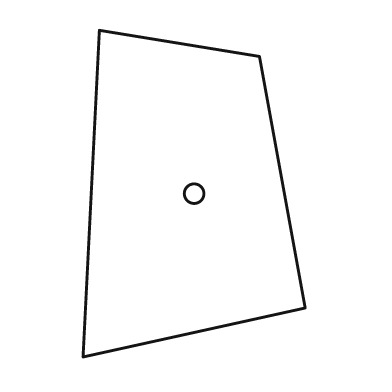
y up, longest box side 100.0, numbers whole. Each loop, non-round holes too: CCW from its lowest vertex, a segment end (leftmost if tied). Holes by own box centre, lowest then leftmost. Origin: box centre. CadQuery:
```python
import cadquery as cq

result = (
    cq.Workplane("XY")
    .moveTo(-34.0, -50.0)
    .lineTo(34.0, -35.0)
    .lineTo(20.0, 42.0)
    .lineTo(-29.0, 50.0)
    .close()
    .moveTo(0.0, 0.0)
    .circle(3.0)
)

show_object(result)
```